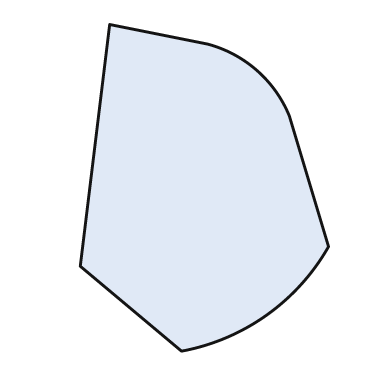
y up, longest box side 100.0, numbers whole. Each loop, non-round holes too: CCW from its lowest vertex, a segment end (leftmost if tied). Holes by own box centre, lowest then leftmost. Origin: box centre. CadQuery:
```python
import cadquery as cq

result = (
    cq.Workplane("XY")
    .moveTo(-7.0, -50.0)
    .threePointArc((19.0, -39.0), (38.0, -18.0))
    .lineTo(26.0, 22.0)
    .threePointArc((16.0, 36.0), (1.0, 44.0))
    .lineTo(-29.0, 50.0)
    .lineTo(-38.0, -24.0)
    .close()
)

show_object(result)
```